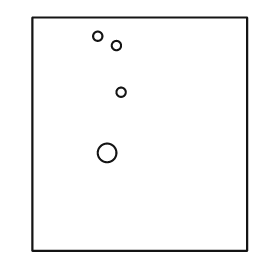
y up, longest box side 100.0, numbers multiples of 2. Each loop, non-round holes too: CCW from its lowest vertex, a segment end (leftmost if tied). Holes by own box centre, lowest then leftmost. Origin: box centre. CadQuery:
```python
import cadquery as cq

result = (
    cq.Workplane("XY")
    .moveTo(-46.0, -50.0)
    .lineTo(46.0, -50.0)
    .lineTo(46.0, 50.0)
    .lineTo(-46.0, 50.0)
    .close()
    .moveTo(-14.0, -8.0)
    .circle(4.0)
    .moveTo(-8.0, 18.0)
    .circle(2.0)
    .moveTo(-10.0, 38.0)
    .circle(2.0)
    .moveTo(-18.0, 42.0)
    .circle(2.0)
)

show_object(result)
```